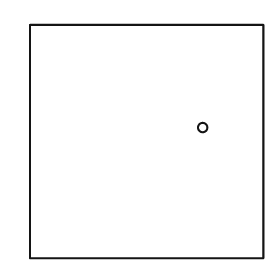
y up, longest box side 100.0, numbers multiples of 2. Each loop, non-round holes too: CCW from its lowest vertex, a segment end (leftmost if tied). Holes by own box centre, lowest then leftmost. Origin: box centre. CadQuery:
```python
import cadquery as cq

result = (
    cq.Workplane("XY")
    .moveTo(-50.0, -50.0)
    .lineTo(50.0, -50.0)
    .lineTo(50.0, 50.0)
    .lineTo(-50.0, 50.0)
    .close()
    .moveTo(24.0, 6.0)
    .circle(2.0)
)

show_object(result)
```